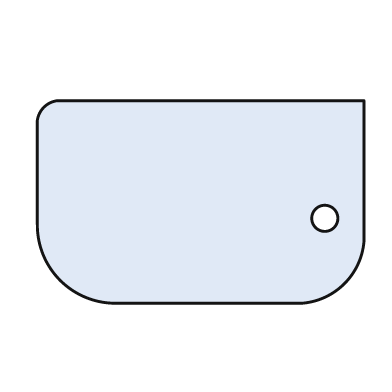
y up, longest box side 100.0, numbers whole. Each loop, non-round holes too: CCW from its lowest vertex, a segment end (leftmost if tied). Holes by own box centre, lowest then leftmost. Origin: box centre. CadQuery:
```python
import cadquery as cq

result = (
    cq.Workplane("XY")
    .moveTo(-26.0, -31.0)
    .lineTo(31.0, -31.0)
    .threePointArc((44.0, -25.0), (50.0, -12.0))
    .lineTo(50.0, 31.0)
    .lineTo(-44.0, 31.0)
    .threePointArc((-48.0, 29.0), (-50.0, 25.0))
    .lineTo(-50.0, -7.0)
    .threePointArc((-43.0, -24.0), (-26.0, -31.0))
    .close()
    .moveTo(38.0, -5.0)
    .circle(4.0)
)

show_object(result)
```